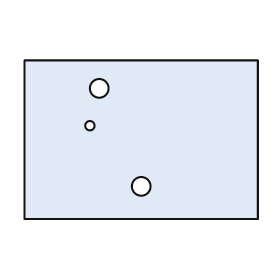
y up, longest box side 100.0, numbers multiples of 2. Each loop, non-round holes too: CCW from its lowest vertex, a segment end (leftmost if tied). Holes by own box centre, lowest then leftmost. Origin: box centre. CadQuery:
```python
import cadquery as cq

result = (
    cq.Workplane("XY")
    .moveTo(-50.0, -34.0)
    .lineTo(50.0, -34.0)
    .lineTo(50.0, 34.0)
    .lineTo(-50.0, 34.0)
    .close()
    .moveTo(0.0, -20.0)
    .circle(4.0)
    .moveTo(-22.0, 6.0)
    .circle(2.0)
    .moveTo(-18.0, 22.0)
    .circle(4.0)
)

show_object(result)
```